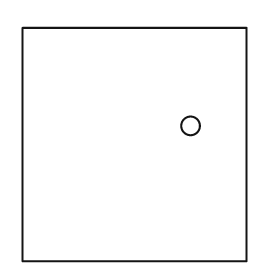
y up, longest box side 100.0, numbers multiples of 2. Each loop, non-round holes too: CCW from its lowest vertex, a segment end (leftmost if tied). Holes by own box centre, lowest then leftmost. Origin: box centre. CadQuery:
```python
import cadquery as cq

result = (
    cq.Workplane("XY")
    .moveTo(-48.0, -50.0)
    .lineTo(48.0, -50.0)
    .lineTo(48.0, 50.0)
    .lineTo(-48.0, 50.0)
    .close()
    .moveTo(24.0, 8.0)
    .circle(4.0)
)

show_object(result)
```